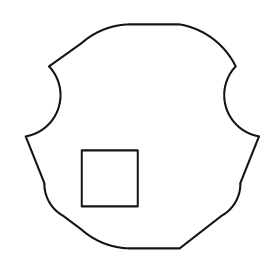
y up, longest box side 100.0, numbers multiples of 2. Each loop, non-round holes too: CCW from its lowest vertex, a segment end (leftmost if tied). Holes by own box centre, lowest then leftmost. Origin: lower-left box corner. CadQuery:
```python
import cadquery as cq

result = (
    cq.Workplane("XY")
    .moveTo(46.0, 0.0)
    .lineTo(66.0, 0.0)
    .lineTo(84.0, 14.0)
    .threePointArc((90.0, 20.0), (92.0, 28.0))
    .lineTo(100.0, 48.0)
    .threePointArc((86.0, 60.0), (90.0, 78.0))
    .threePointArc((80.0, 90.0), (66.0, 96.0))
    .lineTo(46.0, 96.0)
    .threePointArc((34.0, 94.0), (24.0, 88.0))
    .lineTo(10.0, 78.0)
    .threePointArc((14.0, 60.0), (0.0, 48.0))
    .lineTo(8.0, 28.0)
    .threePointArc((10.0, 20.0), (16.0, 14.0))
    .lineTo(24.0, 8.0)
    .threePointArc((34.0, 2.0), (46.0, 0.0))
    .close()
    .moveTo(24.0, 18.0)
    .lineTo(48.0, 18.0)
    .lineTo(48.0, 42.0)
    .lineTo(24.0, 42.0)
    .close()
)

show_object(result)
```